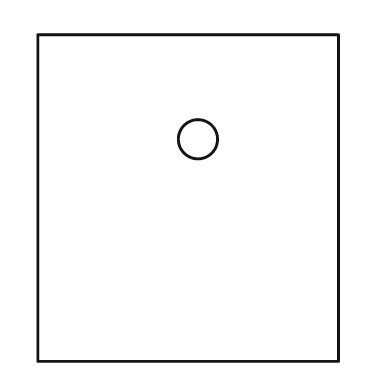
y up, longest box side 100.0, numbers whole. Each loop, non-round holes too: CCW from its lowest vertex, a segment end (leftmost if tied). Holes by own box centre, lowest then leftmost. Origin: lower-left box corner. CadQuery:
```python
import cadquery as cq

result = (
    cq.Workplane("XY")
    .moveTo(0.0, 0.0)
    .lineTo(92.0, 0.0)
    .lineTo(92.0, 100.0)
    .lineTo(0.0, 100.0)
    .close()
    .moveTo(49.0, 68.0)
    .circle(6.0)
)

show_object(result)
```